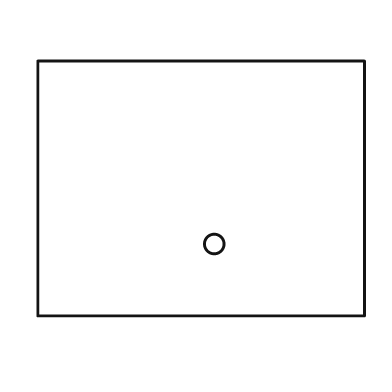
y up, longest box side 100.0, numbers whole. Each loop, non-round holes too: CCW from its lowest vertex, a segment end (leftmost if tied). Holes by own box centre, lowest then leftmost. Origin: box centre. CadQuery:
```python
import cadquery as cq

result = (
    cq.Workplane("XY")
    .moveTo(-50.0, -39.0)
    .lineTo(50.0, -39.0)
    .lineTo(50.0, 39.0)
    .lineTo(-50.0, 39.0)
    .close()
    .moveTo(4.0, -17.0)
    .circle(3.0)
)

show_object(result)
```